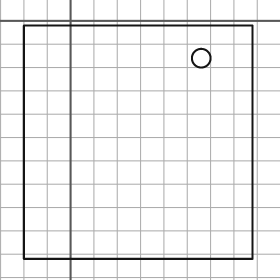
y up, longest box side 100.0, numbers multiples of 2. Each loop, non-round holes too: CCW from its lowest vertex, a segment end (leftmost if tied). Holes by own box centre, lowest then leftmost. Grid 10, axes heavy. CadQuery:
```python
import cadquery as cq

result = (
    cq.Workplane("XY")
    .moveTo(-20.0, -102.0)
    .lineTo(78.0, -102.0)
    .lineTo(78.0, -2.0)
    .lineTo(-20.0, -2.0)
    .close()
    .moveTo(56.0, -16.0)
    .circle(4.0)
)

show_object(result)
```